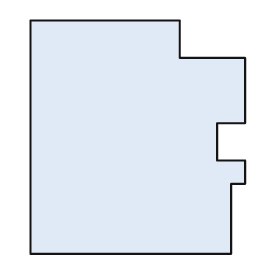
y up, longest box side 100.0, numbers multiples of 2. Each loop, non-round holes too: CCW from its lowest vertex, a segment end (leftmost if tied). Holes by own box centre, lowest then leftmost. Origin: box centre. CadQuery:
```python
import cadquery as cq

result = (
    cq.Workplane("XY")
    .moveTo(-46.0, -50.0)
    .lineTo(40.0, -50.0)
    .lineTo(40.0, -20.0)
    .lineTo(46.0, -20.0)
    .lineTo(46.0, -10.0)
    .lineTo(34.0, -10.0)
    .lineTo(34.0, 6.0)
    .lineTo(46.0, 6.0)
    .lineTo(46.0, 34.0)
    .lineTo(18.0, 34.0)
    .lineTo(18.0, 50.0)
    .lineTo(-46.0, 50.0)
    .close()
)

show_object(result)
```